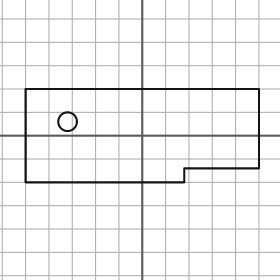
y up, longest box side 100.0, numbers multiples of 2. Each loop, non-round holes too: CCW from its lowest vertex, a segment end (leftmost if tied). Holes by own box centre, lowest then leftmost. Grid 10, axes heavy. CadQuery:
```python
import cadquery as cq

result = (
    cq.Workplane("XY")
    .moveTo(-50.0, -20.0)
    .lineTo(18.0, -20.0)
    .lineTo(18.0, -14.0)
    .lineTo(50.0, -14.0)
    .lineTo(50.0, 20.0)
    .lineTo(-50.0, 20.0)
    .close()
    .moveTo(-32.0, 6.0)
    .circle(4.0)
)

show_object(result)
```